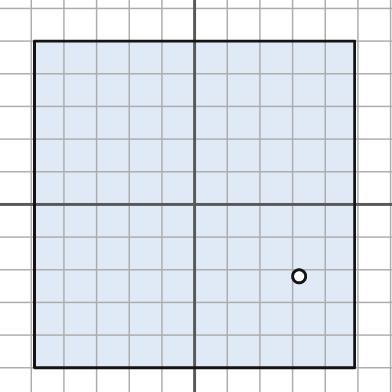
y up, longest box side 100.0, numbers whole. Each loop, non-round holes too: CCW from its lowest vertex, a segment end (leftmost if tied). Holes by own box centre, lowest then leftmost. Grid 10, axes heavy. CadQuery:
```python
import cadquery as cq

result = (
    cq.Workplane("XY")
    .moveTo(-49.0, -50.0)
    .lineTo(49.0, -50.0)
    .lineTo(49.0, 50.0)
    .lineTo(-49.0, 50.0)
    .close()
    .moveTo(32.0, -22.0)
    .circle(2.0)
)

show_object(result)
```